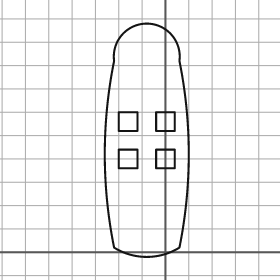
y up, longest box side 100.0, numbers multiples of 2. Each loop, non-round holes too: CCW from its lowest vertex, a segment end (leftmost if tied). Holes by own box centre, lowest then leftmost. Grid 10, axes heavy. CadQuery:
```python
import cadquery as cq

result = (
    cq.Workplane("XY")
    .moveTo(-22.0, 2.0)
    .threePointArc((-8.0, -2.0), (6.0, 2.0))
    .threePointArc((10.0, 42.0), (6.0, 82.0))
    .threePointArc((-8.0, 98.0), (-22.0, 82.0))
    .threePointArc((-26.0, 42.0), (-22.0, 2.0))
    .close()
    .moveTo(-20.0, 36.0)
    .lineTo(-12.0, 36.0)
    .lineTo(-12.0, 44.0)
    .lineTo(-20.0, 44.0)
    .close()
    .moveTo(-4.0, 36.0)
    .lineTo(4.0, 36.0)
    .lineTo(4.0, 44.0)
    .lineTo(-4.0, 44.0)
    .close()
    .moveTo(-20.0, 52.0)
    .lineTo(-12.0, 52.0)
    .lineTo(-12.0, 60.0)
    .lineTo(-20.0, 60.0)
    .close()
    .moveTo(-4.0, 52.0)
    .lineTo(4.0, 52.0)
    .lineTo(4.0, 60.0)
    .lineTo(-4.0, 60.0)
    .close()
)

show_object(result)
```